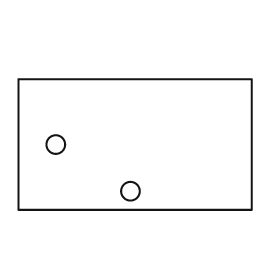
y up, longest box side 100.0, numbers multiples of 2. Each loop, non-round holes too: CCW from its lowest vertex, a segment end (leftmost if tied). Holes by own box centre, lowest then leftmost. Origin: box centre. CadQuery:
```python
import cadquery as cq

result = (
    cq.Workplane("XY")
    .moveTo(-50.0, -28.0)
    .lineTo(50.0, -28.0)
    .lineTo(50.0, 28.0)
    .lineTo(-50.0, 28.0)
    .close()
    .moveTo(-2.0, -20.0)
    .circle(4.0)
    .moveTo(-34.0, 0.0)
    .circle(4.0)
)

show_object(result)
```